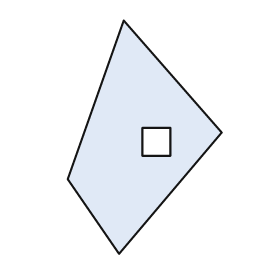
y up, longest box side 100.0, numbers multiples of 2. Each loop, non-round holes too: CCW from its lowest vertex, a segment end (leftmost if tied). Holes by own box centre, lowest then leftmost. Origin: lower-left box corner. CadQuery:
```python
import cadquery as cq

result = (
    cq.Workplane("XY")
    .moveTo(22.0, 0.0)
    .lineTo(66.0, 52.0)
    .lineTo(24.0, 100.0)
    .lineTo(0.0, 32.0)
    .close()
    .moveTo(32.0, 42.0)
    .lineTo(44.0, 42.0)
    .lineTo(44.0, 54.0)
    .lineTo(32.0, 54.0)
    .close()
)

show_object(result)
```